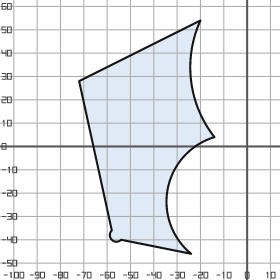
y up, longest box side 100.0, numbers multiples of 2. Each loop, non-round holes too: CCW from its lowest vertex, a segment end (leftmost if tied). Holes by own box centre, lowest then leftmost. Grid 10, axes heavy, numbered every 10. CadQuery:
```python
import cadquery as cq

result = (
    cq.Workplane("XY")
    .moveTo(-24.0, -46.0)
    .threePointArc((-34.0, -18.0), (-14.0, 4.0))
    .threePointArc((-24.0, 28.0), (-20.0, 54.0))
    .lineTo(-72.0, 28.0)
    .lineTo(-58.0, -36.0)
    .threePointArc((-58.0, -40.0), (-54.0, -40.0))
    .close()
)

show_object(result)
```